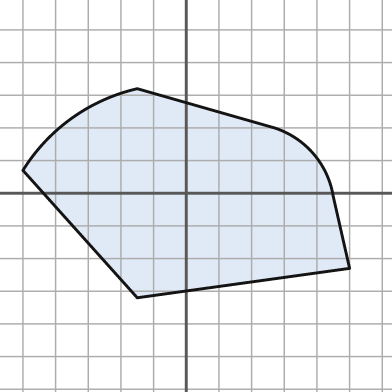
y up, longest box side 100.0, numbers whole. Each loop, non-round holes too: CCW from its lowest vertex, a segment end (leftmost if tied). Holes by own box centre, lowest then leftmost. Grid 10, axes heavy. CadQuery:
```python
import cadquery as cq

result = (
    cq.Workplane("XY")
    .moveTo(-15.0, -32.0)
    .lineTo(50.0, -23.0)
    .lineTo(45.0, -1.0)
    .threePointArc((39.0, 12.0), (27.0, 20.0))
    .lineTo(-15.0, 32.0)
    .threePointArc((-35.0, 23.0), (-50.0, 7.0))
    .close()
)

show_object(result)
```